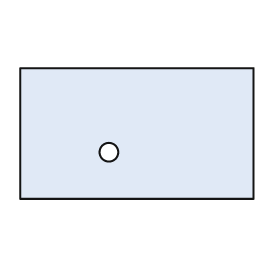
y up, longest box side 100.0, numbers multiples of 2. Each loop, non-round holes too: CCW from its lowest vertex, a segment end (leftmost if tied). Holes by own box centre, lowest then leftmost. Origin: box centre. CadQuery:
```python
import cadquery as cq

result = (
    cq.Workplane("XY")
    .moveTo(-50.0, -28.0)
    .lineTo(50.0, -28.0)
    .lineTo(50.0, 28.0)
    .lineTo(-50.0, 28.0)
    .close()
    .moveTo(-12.0, -8.0)
    .circle(4.0)
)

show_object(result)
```